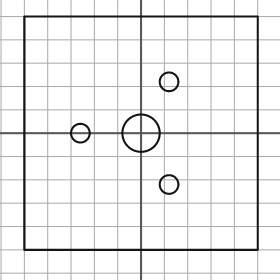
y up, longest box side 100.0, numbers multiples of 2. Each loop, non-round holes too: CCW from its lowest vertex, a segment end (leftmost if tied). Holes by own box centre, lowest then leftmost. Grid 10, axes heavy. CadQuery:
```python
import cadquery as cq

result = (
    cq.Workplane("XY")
    .moveTo(-50.0, -50.0)
    .lineTo(50.0, -50.0)
    .lineTo(50.0, 50.0)
    .lineTo(-50.0, 50.0)
    .close()
    .moveTo(12.0, -22.0)
    .circle(4.0)
    .moveTo(-26.0, 0.0)
    .circle(4.0)
    .moveTo(0.0, 0.0)
    .circle(8.0)
    .moveTo(12.0, 22.0)
    .circle(4.0)
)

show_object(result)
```